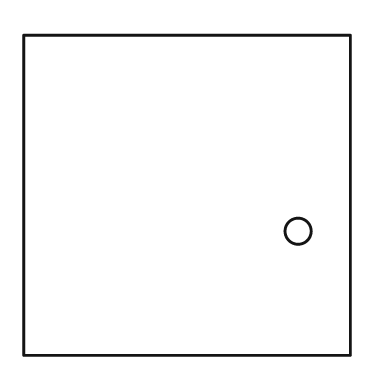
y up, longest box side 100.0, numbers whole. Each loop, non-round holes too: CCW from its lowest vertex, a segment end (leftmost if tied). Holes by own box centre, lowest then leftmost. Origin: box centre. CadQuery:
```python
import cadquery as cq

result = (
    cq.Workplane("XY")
    .moveTo(-50.0, -49.0)
    .lineTo(50.0, -49.0)
    .lineTo(50.0, 49.0)
    .lineTo(-50.0, 49.0)
    .close()
    .moveTo(34.0, -11.0)
    .circle(4.0)
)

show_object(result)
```